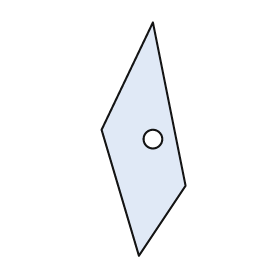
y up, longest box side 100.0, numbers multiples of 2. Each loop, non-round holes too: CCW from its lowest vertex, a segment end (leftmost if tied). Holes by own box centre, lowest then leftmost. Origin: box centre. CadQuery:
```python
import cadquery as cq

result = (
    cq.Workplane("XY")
    .moveTo(-2.0, -50.0)
    .lineTo(18.0, -20.0)
    .lineTo(4.0, 50.0)
    .lineTo(-18.0, 4.0)
    .close()
    .moveTo(4.0, 0.0)
    .circle(4.0)
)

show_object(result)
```